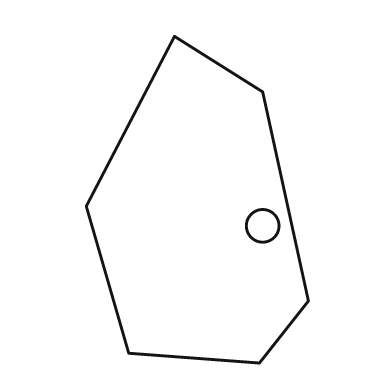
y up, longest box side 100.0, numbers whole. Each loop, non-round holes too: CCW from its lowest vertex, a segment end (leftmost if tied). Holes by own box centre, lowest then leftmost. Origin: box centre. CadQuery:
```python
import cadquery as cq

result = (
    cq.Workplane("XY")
    .moveTo(19.0, -50.0)
    .lineTo(34.0, -31.0)
    .lineTo(20.0, 33.0)
    .lineTo(-7.0, 50.0)
    .lineTo(-34.0, -2.0)
    .lineTo(-21.0, -47.0)
    .close()
    .moveTo(20.0, -8.0)
    .circle(5.0)
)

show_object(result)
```